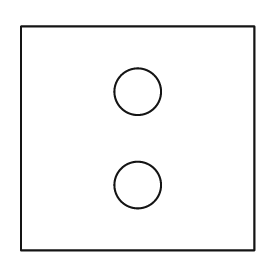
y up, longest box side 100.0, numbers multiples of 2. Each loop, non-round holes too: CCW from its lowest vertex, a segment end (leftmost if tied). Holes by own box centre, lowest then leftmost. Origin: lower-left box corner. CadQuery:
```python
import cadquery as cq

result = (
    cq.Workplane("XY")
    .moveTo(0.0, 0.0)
    .lineTo(100.0, 0.0)
    .lineTo(100.0, 96.0)
    .lineTo(0.0, 96.0)
    .close()
    .moveTo(50.0, 28.0)
    .circle(10.0)
    .moveTo(50.0, 68.0)
    .circle(10.0)
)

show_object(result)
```